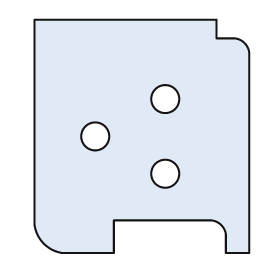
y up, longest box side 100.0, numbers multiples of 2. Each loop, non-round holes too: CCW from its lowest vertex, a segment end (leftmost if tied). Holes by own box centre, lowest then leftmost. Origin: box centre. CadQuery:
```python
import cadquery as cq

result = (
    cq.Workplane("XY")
    .moveTo(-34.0, -50.0)
    .lineTo(-12.0, -50.0)
    .lineTo(-12.0, -36.0)
    .lineTo(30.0, -36.0)
    .threePointArc((34.0, -38.0), (36.0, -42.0))
    .lineTo(36.0, -50.0)
    .lineTo(46.0, -50.0)
    .lineTo(46.0, 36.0)
    .threePointArc((44.0, 40.0), (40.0, 42.0))
    .lineTo(32.0, 42.0)
    .lineTo(32.0, 50.0)
    .lineTo(-46.0, 50.0)
    .lineTo(-46.0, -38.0)
    .threePointArc((-42.0, -46.0), (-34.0, -50.0))
    .close()
    .moveTo(10.0, -16.0)
    .circle(6.0)
    .moveTo(-20.0, 0.0)
    .circle(6.0)
    .moveTo(10.0, 16.0)
    .circle(6.0)
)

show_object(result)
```